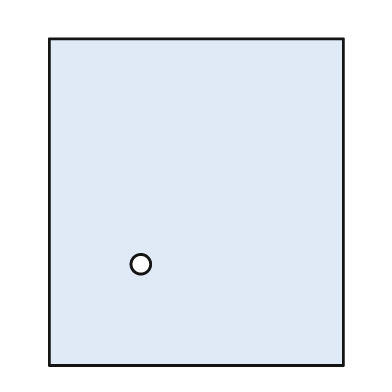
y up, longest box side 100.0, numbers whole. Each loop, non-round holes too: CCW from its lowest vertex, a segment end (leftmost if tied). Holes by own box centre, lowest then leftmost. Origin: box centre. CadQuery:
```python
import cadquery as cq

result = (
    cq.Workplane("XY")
    .moveTo(-45.0, -50.0)
    .lineTo(45.0, -50.0)
    .lineTo(45.0, 50.0)
    .lineTo(-45.0, 50.0)
    .close()
    .moveTo(-17.0, -19.0)
    .circle(3.0)
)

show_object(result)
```